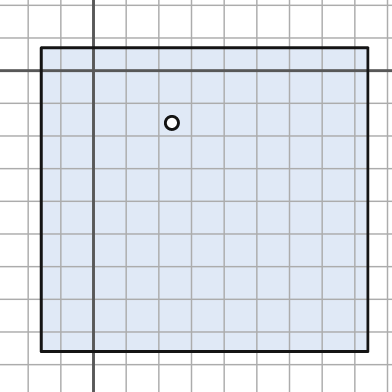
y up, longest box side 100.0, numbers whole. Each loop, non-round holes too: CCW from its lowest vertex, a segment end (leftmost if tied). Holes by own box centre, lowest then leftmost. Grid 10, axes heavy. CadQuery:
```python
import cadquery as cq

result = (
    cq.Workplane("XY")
    .moveTo(-16.0, -86.0)
    .lineTo(84.0, -86.0)
    .lineTo(84.0, 7.0)
    .lineTo(-16.0, 7.0)
    .close()
    .moveTo(24.0, -16.0)
    .circle(2.0)
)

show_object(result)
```